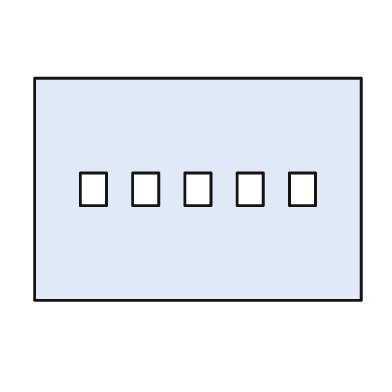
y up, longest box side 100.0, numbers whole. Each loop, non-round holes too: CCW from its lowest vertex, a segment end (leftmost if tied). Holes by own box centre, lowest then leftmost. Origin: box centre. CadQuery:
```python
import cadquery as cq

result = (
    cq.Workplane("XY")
    .moveTo(-50.0, -34.0)
    .lineTo(50.0, -34.0)
    .lineTo(50.0, 34.0)
    .lineTo(-50.0, 34.0)
    .close()
    .moveTo(-36.0, -5.0)
    .lineTo(-28.0, -5.0)
    .lineTo(-28.0, 5.0)
    .lineTo(-36.0, 5.0)
    .close()
    .moveTo(-20.0, -5.0)
    .lineTo(-12.0, -5.0)
    .lineTo(-12.0, 5.0)
    .lineTo(-20.0, 5.0)
    .close()
    .moveTo(-4.0, -5.0)
    .lineTo(4.0, -5.0)
    .lineTo(4.0, 5.0)
    .lineTo(-4.0, 5.0)
    .close()
    .moveTo(12.0, -5.0)
    .lineTo(20.0, -5.0)
    .lineTo(20.0, 5.0)
    .lineTo(12.0, 5.0)
    .close()
    .moveTo(28.0, -5.0)
    .lineTo(36.0, -5.0)
    .lineTo(36.0, 5.0)
    .lineTo(28.0, 5.0)
    .close()
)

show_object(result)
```